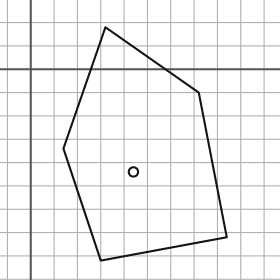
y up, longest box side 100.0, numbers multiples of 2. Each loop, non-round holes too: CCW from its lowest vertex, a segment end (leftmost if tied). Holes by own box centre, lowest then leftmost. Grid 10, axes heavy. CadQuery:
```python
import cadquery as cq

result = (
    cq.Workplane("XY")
    .moveTo(30.0, -82.0)
    .lineTo(84.0, -72.0)
    .lineTo(72.0, -10.0)
    .lineTo(32.0, 18.0)
    .lineTo(14.0, -34.0)
    .close()
    .moveTo(44.0, -44.0)
    .circle(2.0)
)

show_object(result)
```